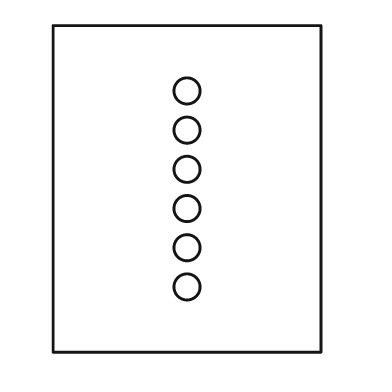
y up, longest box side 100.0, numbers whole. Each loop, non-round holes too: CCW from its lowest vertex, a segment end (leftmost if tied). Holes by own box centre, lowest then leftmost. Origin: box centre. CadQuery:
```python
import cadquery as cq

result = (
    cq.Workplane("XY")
    .moveTo(-41.0, -50.0)
    .lineTo(41.0, -50.0)
    .lineTo(41.0, 50.0)
    .lineTo(-41.0, 50.0)
    .close()
    .moveTo(0.0, -30.0)
    .circle(4.0)
    .moveTo(0.0, -18.0)
    .circle(4.0)
    .moveTo(0.0, -6.0)
    .circle(4.0)
    .moveTo(0.0, 6.0)
    .circle(4.0)
    .moveTo(0.0, 18.0)
    .circle(4.0)
    .moveTo(0.0, 30.0)
    .circle(4.0)
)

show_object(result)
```